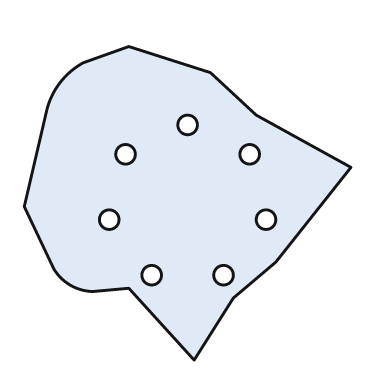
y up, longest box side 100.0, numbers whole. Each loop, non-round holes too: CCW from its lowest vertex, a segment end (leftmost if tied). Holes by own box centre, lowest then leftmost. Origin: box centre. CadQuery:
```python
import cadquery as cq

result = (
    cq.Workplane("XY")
    .moveTo(2.0, -48.0)
    .lineTo(14.0, -29.0)
    .lineTo(27.0, -18.0)
    .lineTo(50.0, 11.0)
    .lineTo(21.0, 27.0)
    .lineTo(7.0, 40.0)
    .lineTo(-18.0, 48.0)
    .lineTo(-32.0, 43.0)
    .threePointArc((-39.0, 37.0), (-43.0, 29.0))
    .lineTo(-50.0, -1.0)
    .lineTo(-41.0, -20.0)
    .threePointArc((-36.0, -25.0), (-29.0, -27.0))
    .lineTo(-18.0, -26.0)
    .close()
    .moveTo(-11.0, -22.0)
    .circle(3.0)
    .moveTo(11.0, -22.0)
    .circle(3.0)
    .moveTo(-24.0, -5.0)
    .circle(3.0)
    .moveTo(24.0, -5.0)
    .circle(3.0)
    .moveTo(-19.0, 15.0)
    .circle(3.0)
    .moveTo(19.0, 15.0)
    .circle(3.0)
    .moveTo(0.0, 24.0)
    .circle(3.0)
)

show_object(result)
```